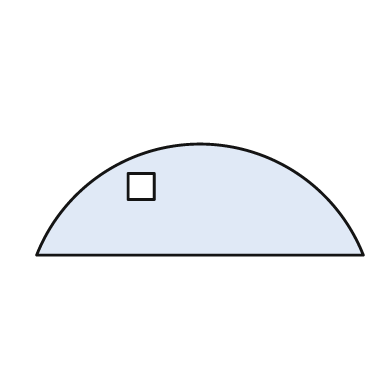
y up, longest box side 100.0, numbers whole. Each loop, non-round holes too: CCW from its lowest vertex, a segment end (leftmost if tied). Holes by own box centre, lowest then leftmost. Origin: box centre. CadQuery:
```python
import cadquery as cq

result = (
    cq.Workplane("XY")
    .moveTo(-50.0, -17.0)
    .lineTo(50.0, -17.0)
    .threePointArc((0.0, 17.0), (-50.0, -17.0))
    .close()
    .moveTo(-22.0, 0.0)
    .lineTo(-14.0, 0.0)
    .lineTo(-14.0, 8.0)
    .lineTo(-22.0, 8.0)
    .close()
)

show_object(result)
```